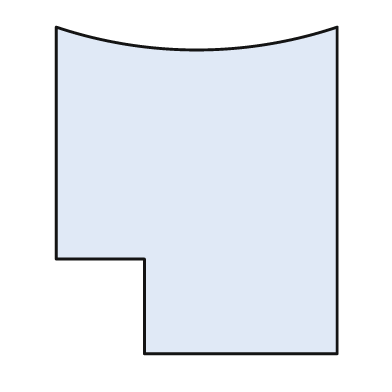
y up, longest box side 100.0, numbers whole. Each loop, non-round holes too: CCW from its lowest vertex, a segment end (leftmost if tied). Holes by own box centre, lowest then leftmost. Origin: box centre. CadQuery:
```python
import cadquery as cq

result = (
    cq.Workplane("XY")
    .moveTo(-16.0, -50.0)
    .lineTo(43.0, -50.0)
    .lineTo(43.0, 50.0)
    .threePointArc((0.0, 43.0), (-43.0, 50.0))
    .lineTo(-43.0, -21.0)
    .lineTo(-16.0, -21.0)
    .close()
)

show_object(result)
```